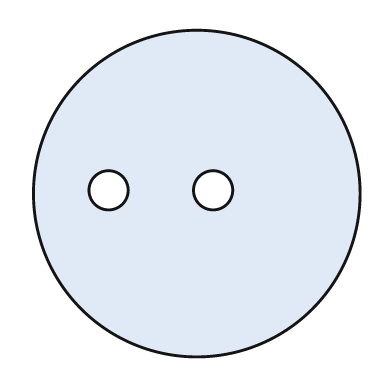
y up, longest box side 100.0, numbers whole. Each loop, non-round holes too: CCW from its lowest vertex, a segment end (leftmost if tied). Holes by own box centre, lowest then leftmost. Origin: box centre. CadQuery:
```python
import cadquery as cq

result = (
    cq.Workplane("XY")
    .moveTo(0.0, 0.0)
    .circle(50.0)
    .moveTo(-27.0, 1.0)
    .circle(6.0)
    .moveTo(5.0, 1.0)
    .circle(6.0)
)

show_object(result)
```